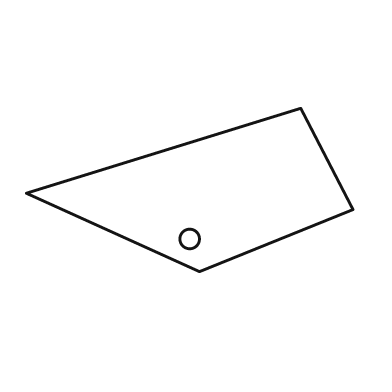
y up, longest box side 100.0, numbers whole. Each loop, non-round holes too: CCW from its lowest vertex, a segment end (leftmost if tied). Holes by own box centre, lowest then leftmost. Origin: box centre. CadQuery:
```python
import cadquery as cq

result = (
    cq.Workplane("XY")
    .moveTo(3.0, -25.0)
    .lineTo(50.0, -6.0)
    .lineTo(34.0, 25.0)
    .lineTo(-50.0, -1.0)
    .close()
    .moveTo(0.0, -15.0)
    .circle(3.0)
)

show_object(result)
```